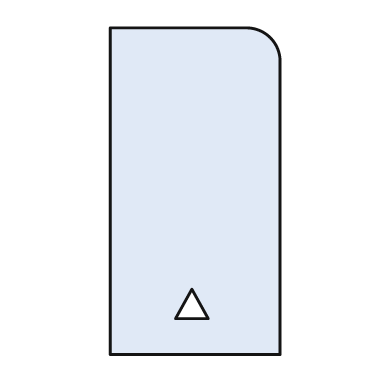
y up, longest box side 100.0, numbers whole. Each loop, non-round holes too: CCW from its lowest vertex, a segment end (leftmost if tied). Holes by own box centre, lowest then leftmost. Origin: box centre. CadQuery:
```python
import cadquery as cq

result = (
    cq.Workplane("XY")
    .moveTo(-26.0, -50.0)
    .lineTo(26.0, -50.0)
    .lineTo(26.0, 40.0)
    .threePointArc((23.0, 47.0), (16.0, 50.0))
    .lineTo(-26.0, 50.0)
    .close()
    .moveTo(-6.0, -39.0)
    .lineTo(4.0, -39.0)
    .lineTo(-1.0, -30.0)
    .close()
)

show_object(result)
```